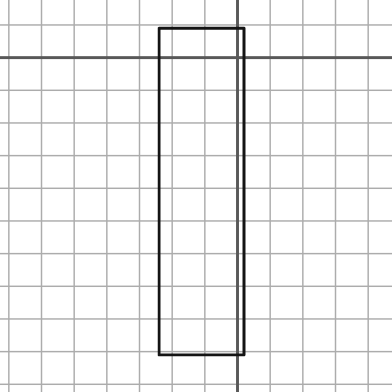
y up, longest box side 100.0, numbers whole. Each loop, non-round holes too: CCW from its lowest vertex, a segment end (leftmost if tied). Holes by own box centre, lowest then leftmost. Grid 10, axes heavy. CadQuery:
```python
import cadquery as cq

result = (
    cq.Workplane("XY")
    .moveTo(-24.0, -91.0)
    .lineTo(2.0, -91.0)
    .lineTo(2.0, 9.0)
    .lineTo(-24.0, 9.0)
    .close()
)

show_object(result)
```